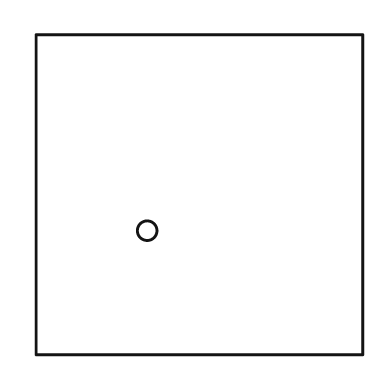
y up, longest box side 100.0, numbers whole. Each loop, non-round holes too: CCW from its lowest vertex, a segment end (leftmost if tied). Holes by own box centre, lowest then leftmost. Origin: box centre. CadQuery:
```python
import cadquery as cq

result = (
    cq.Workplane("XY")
    .moveTo(-50.0, -49.0)
    .lineTo(50.0, -49.0)
    .lineTo(50.0, 49.0)
    .lineTo(-50.0, 49.0)
    .close()
    .moveTo(-16.0, -11.0)
    .circle(3.0)
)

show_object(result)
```